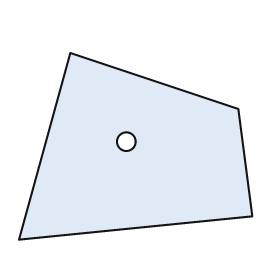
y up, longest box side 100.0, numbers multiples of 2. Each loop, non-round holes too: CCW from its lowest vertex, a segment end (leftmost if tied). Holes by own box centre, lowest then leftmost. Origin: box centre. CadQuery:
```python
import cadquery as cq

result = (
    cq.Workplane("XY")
    .moveTo(-50.0, -40.0)
    .lineTo(50.0, -30.0)
    .lineTo(44.0, 16.0)
    .lineTo(-28.0, 40.0)
    .close()
    .moveTo(-4.0, 2.0)
    .circle(4.0)
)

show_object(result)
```